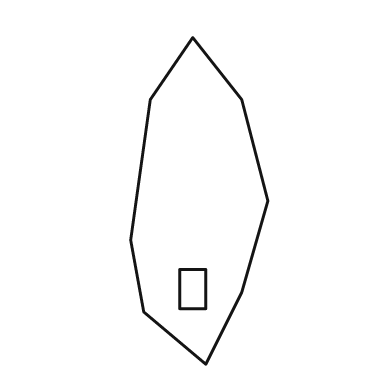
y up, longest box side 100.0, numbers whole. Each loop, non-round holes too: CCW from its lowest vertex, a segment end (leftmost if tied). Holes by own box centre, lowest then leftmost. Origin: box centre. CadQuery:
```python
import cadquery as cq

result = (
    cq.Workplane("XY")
    .moveTo(2.0, -50.0)
    .lineTo(13.0, -28.0)
    .lineTo(21.0, 0.0)
    .lineTo(13.0, 31.0)
    .lineTo(-2.0, 50.0)
    .lineTo(-15.0, 31.0)
    .lineTo(-21.0, -12.0)
    .lineTo(-17.0, -34.0)
    .close()
    .moveTo(-6.0, -33.0)
    .lineTo(2.0, -33.0)
    .lineTo(2.0, -21.0)
    .lineTo(-6.0, -21.0)
    .close()
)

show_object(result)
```